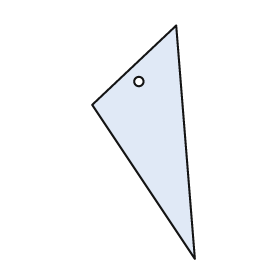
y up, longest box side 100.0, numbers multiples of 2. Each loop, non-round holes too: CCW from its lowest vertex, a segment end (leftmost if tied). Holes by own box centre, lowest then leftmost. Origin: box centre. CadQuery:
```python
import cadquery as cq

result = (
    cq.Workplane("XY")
    .moveTo(22.0, -50.0)
    .lineTo(14.0, 50.0)
    .lineTo(-22.0, 16.0)
    .close()
    .moveTo(-2.0, 26.0)
    .circle(2.0)
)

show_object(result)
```